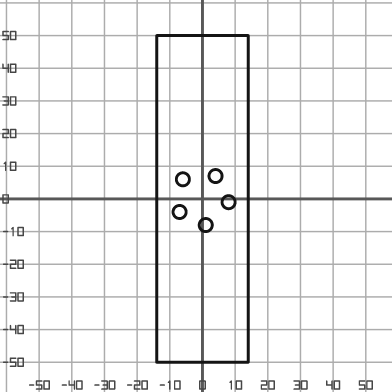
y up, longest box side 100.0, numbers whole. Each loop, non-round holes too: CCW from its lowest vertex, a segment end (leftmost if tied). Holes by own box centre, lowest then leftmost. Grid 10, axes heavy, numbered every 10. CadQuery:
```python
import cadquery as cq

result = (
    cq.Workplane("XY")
    .moveTo(-14.0, -50.0)
    .lineTo(14.0, -50.0)
    .lineTo(14.0, 50.0)
    .lineTo(-14.0, 50.0)
    .close()
    .moveTo(1.0, -8.0)
    .circle(2.0)
    .moveTo(-7.0, -4.0)
    .circle(2.0)
    .moveTo(8.0, -1.0)
    .circle(2.0)
    .moveTo(-6.0, 6.0)
    .circle(2.0)
    .moveTo(4.0, 7.0)
    .circle(2.0)
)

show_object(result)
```